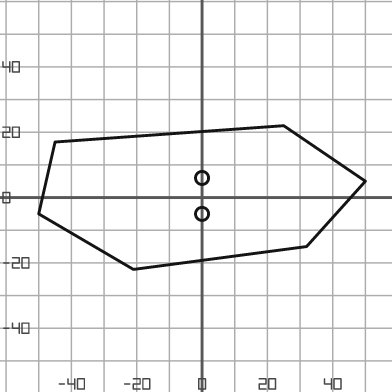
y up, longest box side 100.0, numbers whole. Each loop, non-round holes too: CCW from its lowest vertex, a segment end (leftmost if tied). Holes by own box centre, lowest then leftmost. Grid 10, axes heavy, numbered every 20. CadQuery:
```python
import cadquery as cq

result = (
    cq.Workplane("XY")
    .moveTo(-21.0, -22.0)
    .lineTo(32.0, -15.0)
    .lineTo(50.0, 5.0)
    .lineTo(25.0, 22.0)
    .lineTo(-45.0, 17.0)
    .lineTo(-50.0, -5.0)
    .close()
    .moveTo(0.0, -5.0)
    .circle(2.0)
    .moveTo(0.0, 6.0)
    .circle(2.0)
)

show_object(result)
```